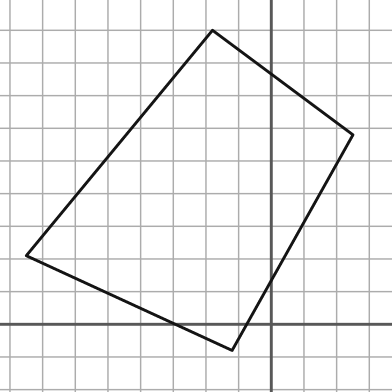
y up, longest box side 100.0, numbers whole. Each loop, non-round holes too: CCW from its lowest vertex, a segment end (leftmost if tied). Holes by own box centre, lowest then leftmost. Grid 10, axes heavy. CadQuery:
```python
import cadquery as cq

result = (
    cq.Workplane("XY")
    .moveTo(-12.0, -8.0)
    .lineTo(25.0, 58.0)
    .lineTo(-18.0, 90.0)
    .lineTo(-75.0, 21.0)
    .close()
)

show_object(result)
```